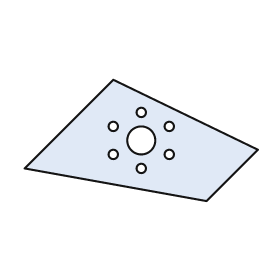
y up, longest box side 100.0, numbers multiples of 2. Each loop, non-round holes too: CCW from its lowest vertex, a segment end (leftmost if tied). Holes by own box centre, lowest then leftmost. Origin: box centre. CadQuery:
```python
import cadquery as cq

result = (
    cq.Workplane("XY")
    .moveTo(28.0, -26.0)
    .lineTo(50.0, -4.0)
    .lineTo(-12.0, 26.0)
    .lineTo(-50.0, -12.0)
    .close()
    .moveTo(0.0, -12.0)
    .circle(2.0)
    .moveTo(-12.0, -6.0)
    .circle(2.0)
    .moveTo(12.0, -6.0)
    .circle(2.0)
    .moveTo(0.0, 0.0)
    .circle(6.0)
    .moveTo(-12.0, 6.0)
    .circle(2.0)
    .moveTo(12.0, 6.0)
    .circle(2.0)
    .moveTo(0.0, 12.0)
    .circle(2.0)
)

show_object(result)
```